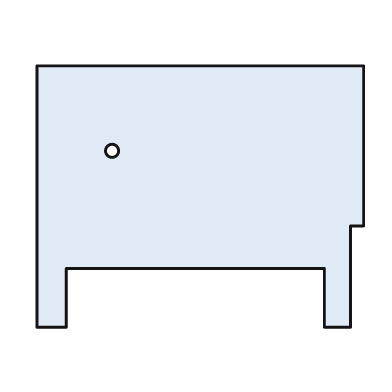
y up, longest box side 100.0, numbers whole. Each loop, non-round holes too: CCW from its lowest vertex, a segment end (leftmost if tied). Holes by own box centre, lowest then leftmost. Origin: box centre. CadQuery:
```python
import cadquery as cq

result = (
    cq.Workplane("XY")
    .moveTo(-50.0, -40.0)
    .lineTo(-41.0, -40.0)
    .lineTo(-41.0, -22.0)
    .lineTo(38.0, -22.0)
    .lineTo(38.0, -40.0)
    .lineTo(46.0, -40.0)
    .lineTo(46.0, -9.0)
    .lineTo(50.0, -9.0)
    .lineTo(50.0, 40.0)
    .lineTo(-50.0, 40.0)
    .close()
    .moveTo(-27.0, 14.0)
    .circle(2.0)
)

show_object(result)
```